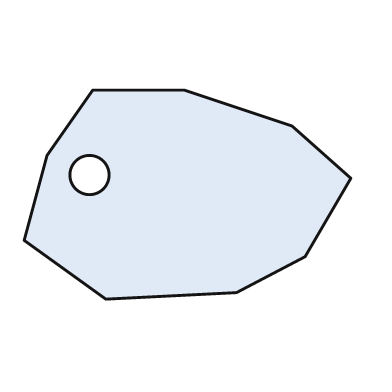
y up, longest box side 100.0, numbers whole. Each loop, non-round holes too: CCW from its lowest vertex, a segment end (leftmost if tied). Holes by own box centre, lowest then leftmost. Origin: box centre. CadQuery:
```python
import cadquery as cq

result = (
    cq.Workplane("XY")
    .moveTo(-25.0, -32.0)
    .lineTo(15.0, -30.0)
    .lineTo(36.0, -19.0)
    .lineTo(50.0, 5.0)
    .lineTo(32.0, 21.0)
    .lineTo(-1.0, 32.0)
    .lineTo(-29.0, 32.0)
    .lineTo(-43.0, 12.0)
    .lineTo(-50.0, -14.0)
    .close()
    .moveTo(-30.0, 6.0)
    .circle(6.0)
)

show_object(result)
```